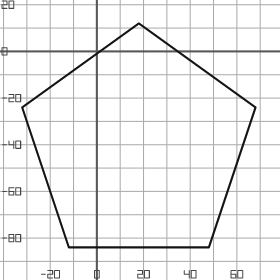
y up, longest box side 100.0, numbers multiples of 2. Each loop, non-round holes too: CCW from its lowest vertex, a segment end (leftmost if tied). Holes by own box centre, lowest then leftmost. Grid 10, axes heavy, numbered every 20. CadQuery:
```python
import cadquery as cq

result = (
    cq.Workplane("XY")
    .moveTo(-12.0, -84.0)
    .lineTo(48.0, -84.0)
    .lineTo(68.0, -24.0)
    .lineTo(18.0, 12.0)
    .lineTo(-32.0, -24.0)
    .close()
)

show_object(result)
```